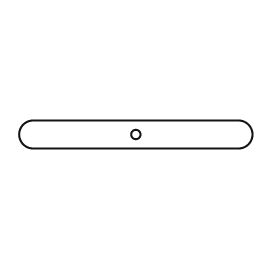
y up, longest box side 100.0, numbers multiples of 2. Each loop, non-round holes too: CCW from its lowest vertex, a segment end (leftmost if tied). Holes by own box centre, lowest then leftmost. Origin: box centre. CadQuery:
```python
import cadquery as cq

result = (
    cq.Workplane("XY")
    .moveTo(-44.0, -6.0)
    .lineTo(44.0, -6.0)
    .threePointArc((50.0, 0.0), (44.0, 6.0))
    .lineTo(-44.0, 6.0)
    .threePointArc((-50.0, 0.0), (-44.0, -6.0))
    .close()
    .moveTo(0.0, 0.0)
    .circle(2.0)
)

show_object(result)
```